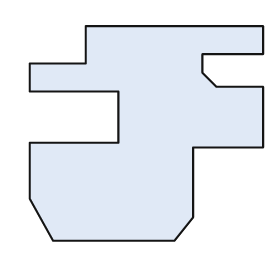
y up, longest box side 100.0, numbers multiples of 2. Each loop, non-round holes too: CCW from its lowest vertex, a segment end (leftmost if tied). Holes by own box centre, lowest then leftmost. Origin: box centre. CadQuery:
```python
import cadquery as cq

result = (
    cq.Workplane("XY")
    .moveTo(-40.0, -46.0)
    .lineTo(12.0, -46.0)
    .lineTo(20.0, -36.0)
    .lineTo(20.0, -6.0)
    .lineTo(50.0, -6.0)
    .lineTo(50.0, 20.0)
    .lineTo(30.0, 20.0)
    .lineTo(24.0, 26.0)
    .lineTo(24.0, 34.0)
    .lineTo(50.0, 34.0)
    .lineTo(50.0, 46.0)
    .lineTo(-26.0, 46.0)
    .lineTo(-26.0, 30.0)
    .lineTo(-50.0, 30.0)
    .lineTo(-50.0, 18.0)
    .lineTo(-12.0, 18.0)
    .lineTo(-12.0, -4.0)
    .lineTo(-50.0, -4.0)
    .lineTo(-50.0, -28.0)
    .close()
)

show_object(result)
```